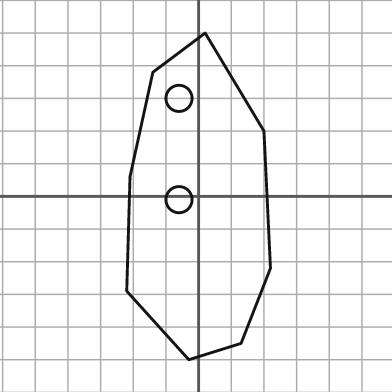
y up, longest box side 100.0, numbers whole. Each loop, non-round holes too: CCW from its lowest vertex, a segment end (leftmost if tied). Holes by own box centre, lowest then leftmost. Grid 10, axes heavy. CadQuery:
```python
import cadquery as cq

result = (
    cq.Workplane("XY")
    .moveTo(-3.0, -50.0)
    .lineTo(13.0, -45.0)
    .lineTo(22.0, -22.0)
    .lineTo(20.0, 20.0)
    .lineTo(2.0, 50.0)
    .lineTo(-14.0, 38.0)
    .lineTo(-21.0, 6.0)
    .lineTo(-22.0, -29.0)
    .close()
    .moveTo(-6.0, -1.0)
    .circle(4.0)
    .moveTo(-6.0, 30.0)
    .circle(4.0)
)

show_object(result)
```